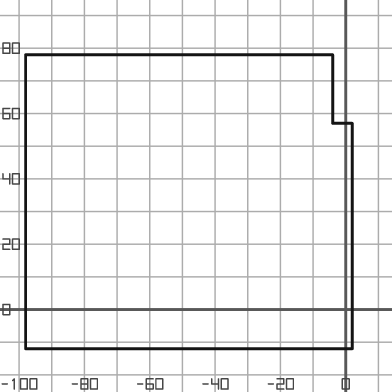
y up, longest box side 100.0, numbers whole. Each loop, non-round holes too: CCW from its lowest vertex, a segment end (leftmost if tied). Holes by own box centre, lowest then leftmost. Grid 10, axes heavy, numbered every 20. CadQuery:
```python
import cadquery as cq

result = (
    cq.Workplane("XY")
    .moveTo(-98.0, -12.0)
    .lineTo(2.0, -12.0)
    .lineTo(2.0, 57.0)
    .lineTo(-4.0, 57.0)
    .lineTo(-4.0, 78.0)
    .lineTo(-98.0, 78.0)
    .close()
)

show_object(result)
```